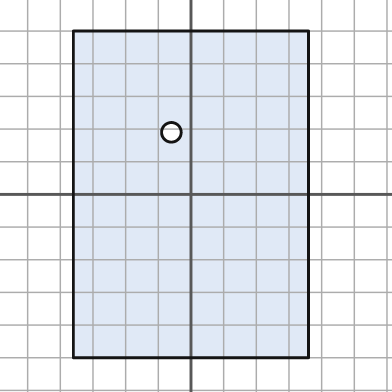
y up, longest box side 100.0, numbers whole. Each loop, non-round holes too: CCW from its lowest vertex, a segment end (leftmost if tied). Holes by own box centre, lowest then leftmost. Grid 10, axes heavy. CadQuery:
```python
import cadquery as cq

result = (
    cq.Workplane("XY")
    .moveTo(-36.0, -50.0)
    .lineTo(36.0, -50.0)
    .lineTo(36.0, 50.0)
    .lineTo(-36.0, 50.0)
    .close()
    .moveTo(-6.0, 19.0)
    .circle(3.0)
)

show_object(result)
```